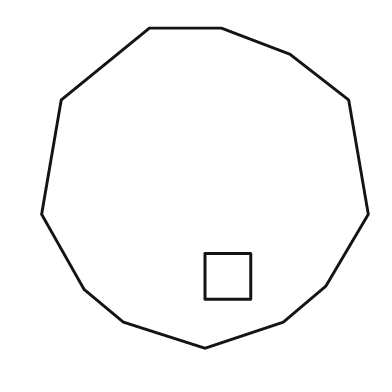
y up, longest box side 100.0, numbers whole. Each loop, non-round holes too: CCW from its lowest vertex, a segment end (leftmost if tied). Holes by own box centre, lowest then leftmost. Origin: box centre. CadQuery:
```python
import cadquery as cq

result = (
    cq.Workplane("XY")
    .moveTo(0.0, -49.0)
    .lineTo(24.0, -41.0)
    .lineTo(37.0, -30.0)
    .lineTo(50.0, -8.0)
    .lineTo(44.0, 27.0)
    .lineTo(26.0, 41.0)
    .lineTo(5.0, 49.0)
    .lineTo(-17.0, 49.0)
    .lineTo(-44.0, 27.0)
    .lineTo(-50.0, -8.0)
    .lineTo(-37.0, -31.0)
    .lineTo(-25.0, -41.0)
    .close()
    .moveTo(0.0, -34.0)
    .lineTo(14.0, -34.0)
    .lineTo(14.0, -20.0)
    .lineTo(0.0, -20.0)
    .close()
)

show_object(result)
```